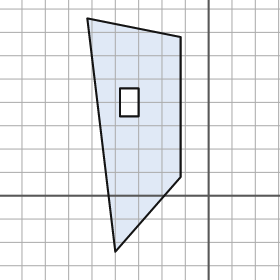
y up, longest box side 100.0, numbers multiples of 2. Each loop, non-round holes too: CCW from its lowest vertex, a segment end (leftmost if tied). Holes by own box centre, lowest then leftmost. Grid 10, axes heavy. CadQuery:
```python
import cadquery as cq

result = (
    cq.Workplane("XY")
    .moveTo(-40.0, -24.0)
    .lineTo(-12.0, 8.0)
    .lineTo(-12.0, 68.0)
    .lineTo(-52.0, 76.0)
    .close()
    .moveTo(-38.0, 34.0)
    .lineTo(-30.0, 34.0)
    .lineTo(-30.0, 46.0)
    .lineTo(-38.0, 46.0)
    .close()
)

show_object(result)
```